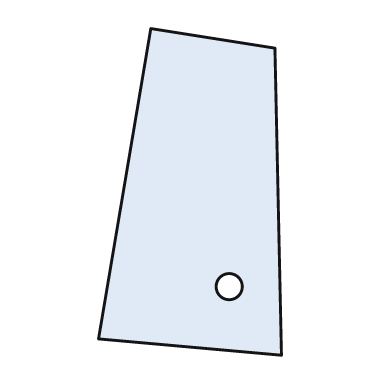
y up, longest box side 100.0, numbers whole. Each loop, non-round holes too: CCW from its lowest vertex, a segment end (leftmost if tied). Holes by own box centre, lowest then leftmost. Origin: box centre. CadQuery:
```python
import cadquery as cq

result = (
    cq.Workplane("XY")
    .moveTo(28.0, -50.0)
    .lineTo(26.0, 44.0)
    .lineTo(-12.0, 50.0)
    .lineTo(-28.0, -45.0)
    .close()
    .moveTo(12.0, -29.0)
    .circle(4.0)
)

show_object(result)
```